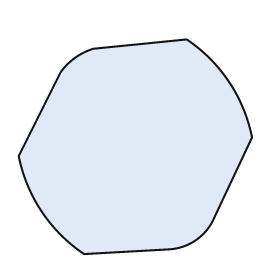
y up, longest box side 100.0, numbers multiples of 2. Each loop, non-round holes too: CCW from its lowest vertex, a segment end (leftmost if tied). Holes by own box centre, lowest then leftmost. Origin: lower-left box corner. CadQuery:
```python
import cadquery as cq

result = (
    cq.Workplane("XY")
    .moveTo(28.0, 0.0)
    .lineTo(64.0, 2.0)
    .threePointArc((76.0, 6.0), (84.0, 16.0))
    .lineTo(100.0, 50.0)
    .threePointArc((90.0, 74.0), (72.0, 92.0))
    .lineTo(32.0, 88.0)
    .threePointArc((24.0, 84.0), (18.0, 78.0))
    .lineTo(0.0, 42.0)
    .threePointArc((10.0, 18.0), (28.0, 0.0))
    .close()
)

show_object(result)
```